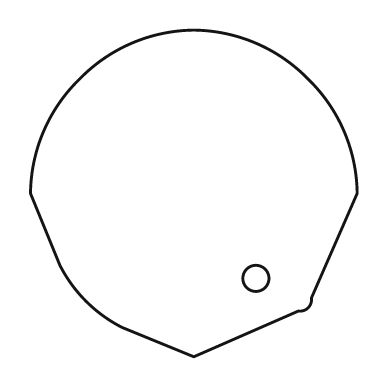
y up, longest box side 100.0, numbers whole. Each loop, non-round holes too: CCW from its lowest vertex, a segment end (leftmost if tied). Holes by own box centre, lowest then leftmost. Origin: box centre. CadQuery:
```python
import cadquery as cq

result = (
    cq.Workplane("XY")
    .moveTo(0.0, -50.0)
    .lineTo(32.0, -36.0)
    .threePointArc((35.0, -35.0), (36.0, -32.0))
    .lineTo(50.0, 0.0)
    .threePointArc((46.0, 19.0), (35.0, 35.0))
    .threePointArc((19.0, 46.0), (0.0, 50.0))
    .threePointArc((-19.0, 46.0), (-35.0, 35.0))
    .threePointArc((-46.0, 19.0), (-50.0, 0.0))
    .lineTo(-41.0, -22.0)
    .threePointArc((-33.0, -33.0), (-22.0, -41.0))
    .close()
    .moveTo(19.0, -26.0)
    .circle(4.0)
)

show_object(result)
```